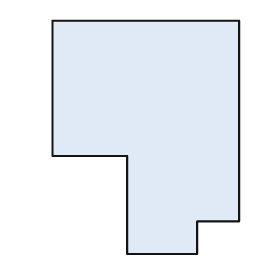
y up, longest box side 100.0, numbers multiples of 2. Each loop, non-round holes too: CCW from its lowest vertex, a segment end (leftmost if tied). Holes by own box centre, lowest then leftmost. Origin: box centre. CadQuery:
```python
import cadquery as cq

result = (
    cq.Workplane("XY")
    .moveTo(-8.0, -50.0)
    .lineTo(22.0, -50.0)
    .lineTo(22.0, -36.0)
    .lineTo(40.0, -36.0)
    .lineTo(40.0, 50.0)
    .lineTo(-40.0, 50.0)
    .lineTo(-40.0, -8.0)
    .lineTo(-8.0, -8.0)
    .close()
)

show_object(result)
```